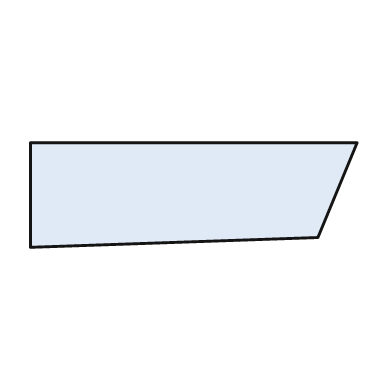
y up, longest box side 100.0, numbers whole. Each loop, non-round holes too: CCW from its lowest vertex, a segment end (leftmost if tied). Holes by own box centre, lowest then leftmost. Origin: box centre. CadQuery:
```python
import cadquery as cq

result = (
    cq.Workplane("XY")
    .moveTo(-50.0, -16.0)
    .lineTo(38.0, -13.0)
    .lineTo(50.0, 16.0)
    .lineTo(-50.0, 16.0)
    .close()
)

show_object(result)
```